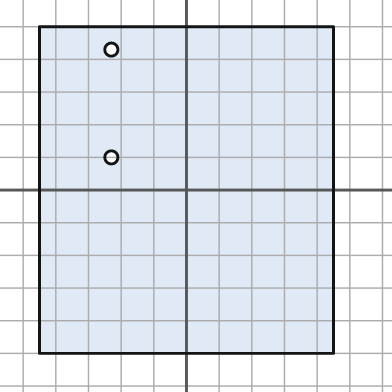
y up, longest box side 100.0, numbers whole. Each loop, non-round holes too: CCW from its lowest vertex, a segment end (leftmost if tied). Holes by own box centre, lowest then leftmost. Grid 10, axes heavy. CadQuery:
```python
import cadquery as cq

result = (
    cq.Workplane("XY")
    .moveTo(-45.0, -50.0)
    .lineTo(45.0, -50.0)
    .lineTo(45.0, 50.0)
    .lineTo(-45.0, 50.0)
    .close()
    .moveTo(-23.0, 10.0)
    .circle(2.0)
    .moveTo(-23.0, 43.0)
    .circle(2.0)
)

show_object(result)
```